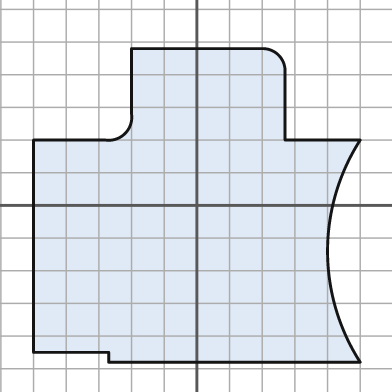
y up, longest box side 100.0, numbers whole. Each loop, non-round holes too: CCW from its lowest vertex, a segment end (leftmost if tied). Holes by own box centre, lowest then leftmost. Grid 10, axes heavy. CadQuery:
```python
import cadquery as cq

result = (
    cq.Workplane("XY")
    .moveTo(-27.0, -48.0)
    .lineTo(50.0, -48.0)
    .threePointArc((40.0, -14.0), (50.0, 20.0))
    .lineTo(27.0, 20.0)
    .lineTo(27.0, 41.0)
    .threePointArc((25.0, 46.0), (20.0, 48.0))
    .lineTo(-20.0, 48.0)
    .lineTo(-20.0, 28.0)
    .threePointArc((-22.0, 22.0), (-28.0, 20.0))
    .lineTo(-50.0, 20.0)
    .lineTo(-50.0, -45.0)
    .lineTo(-27.0, -45.0)
    .close()
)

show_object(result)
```